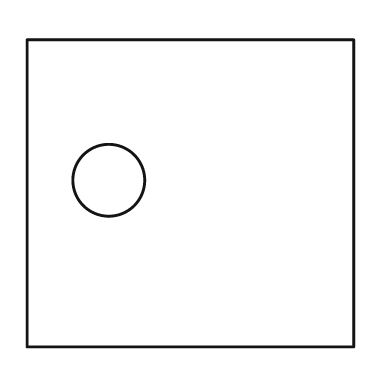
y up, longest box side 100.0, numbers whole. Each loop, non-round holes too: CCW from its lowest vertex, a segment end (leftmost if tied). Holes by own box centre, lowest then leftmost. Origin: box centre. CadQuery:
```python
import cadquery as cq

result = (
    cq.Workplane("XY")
    .moveTo(-50.0, -47.0)
    .lineTo(50.0, -47.0)
    .lineTo(50.0, 47.0)
    .lineTo(-50.0, 47.0)
    .close()
    .moveTo(-25.0, 4.0)
    .circle(11.0)
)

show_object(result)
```